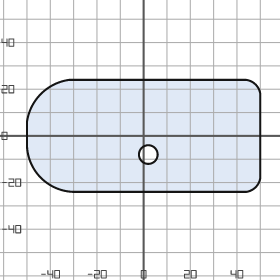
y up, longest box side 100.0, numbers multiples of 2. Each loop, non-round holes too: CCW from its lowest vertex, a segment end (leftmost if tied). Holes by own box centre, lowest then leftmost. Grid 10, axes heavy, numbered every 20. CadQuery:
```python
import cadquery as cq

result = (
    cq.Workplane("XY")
    .moveTo(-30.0, -24.0)
    .lineTo(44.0, -24.0)
    .threePointArc((48.0, -22.0), (50.0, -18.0))
    .lineTo(50.0, 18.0)
    .threePointArc((48.0, 22.0), (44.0, 24.0))
    .lineTo(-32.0, 24.0)
    .threePointArc((-44.0, 18.0), (-50.0, 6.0))
    .lineTo(-50.0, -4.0)
    .threePointArc((-44.0, -18.0), (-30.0, -24.0))
    .close()
    .moveTo(2.0, -8.0)
    .circle(4.0)
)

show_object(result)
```